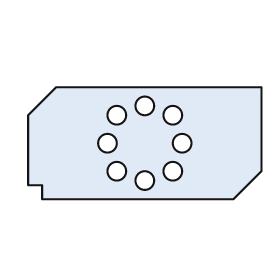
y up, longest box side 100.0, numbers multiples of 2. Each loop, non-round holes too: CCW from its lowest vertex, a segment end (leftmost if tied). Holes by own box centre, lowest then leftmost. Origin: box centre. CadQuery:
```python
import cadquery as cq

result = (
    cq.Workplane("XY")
    .moveTo(-44.0, -24.0)
    .lineTo(38.0, -24.0)
    .lineTo(50.0, -12.0)
    .lineTo(50.0, 24.0)
    .lineTo(-38.0, 24.0)
    .lineTo(-50.0, 12.0)
    .lineTo(-50.0, -18.0)
    .lineTo(-44.0, -18.0)
    .close()
    .moveTo(0.0, -16.0)
    .circle(4.0)
    .moveTo(-12.0, -12.0)
    .circle(4.0)
    .moveTo(12.0, -12.0)
    .circle(4.0)
    .moveTo(-16.0, 0.0)
    .circle(4.0)
    .moveTo(16.0, 0.0)
    .circle(4.0)
    .moveTo(-12.0, 12.0)
    .circle(4.0)
    .moveTo(12.0, 12.0)
    .circle(4.0)
    .moveTo(0.0, 16.0)
    .circle(4.0)
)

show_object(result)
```